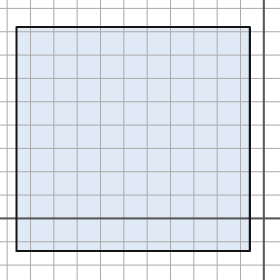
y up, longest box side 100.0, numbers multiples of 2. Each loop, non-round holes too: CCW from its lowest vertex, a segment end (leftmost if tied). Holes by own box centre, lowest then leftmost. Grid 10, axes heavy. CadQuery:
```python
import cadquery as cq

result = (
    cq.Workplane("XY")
    .moveTo(-106.0, -14.0)
    .lineTo(-6.0, -14.0)
    .lineTo(-6.0, 82.0)
    .lineTo(-106.0, 82.0)
    .close()
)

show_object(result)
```